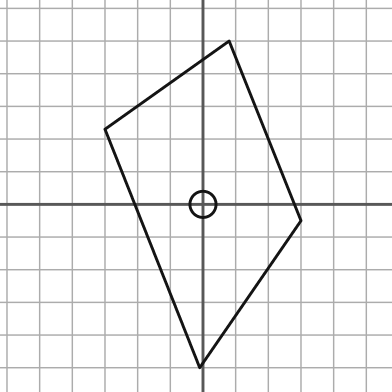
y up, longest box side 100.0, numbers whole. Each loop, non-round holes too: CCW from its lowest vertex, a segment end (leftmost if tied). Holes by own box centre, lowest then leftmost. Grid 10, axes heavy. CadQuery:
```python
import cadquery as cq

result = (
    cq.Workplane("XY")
    .moveTo(-1.0, -50.0)
    .lineTo(30.0, -5.0)
    .lineTo(8.0, 50.0)
    .lineTo(-30.0, 23.0)
    .close()
    .moveTo(0.0, 0.0)
    .circle(4.0)
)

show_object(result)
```